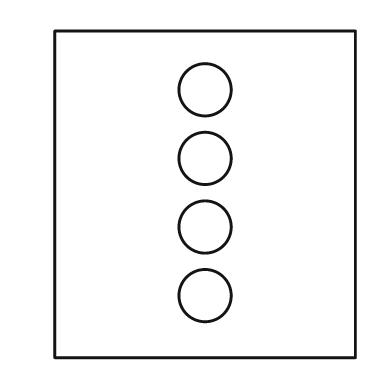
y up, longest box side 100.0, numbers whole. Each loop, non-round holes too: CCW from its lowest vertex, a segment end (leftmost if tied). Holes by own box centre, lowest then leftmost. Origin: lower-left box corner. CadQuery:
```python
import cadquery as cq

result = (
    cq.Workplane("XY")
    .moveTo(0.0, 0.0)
    .lineTo(92.0, 0.0)
    .lineTo(92.0, 100.0)
    .lineTo(0.0, 100.0)
    .close()
    .moveTo(46.0, 19.0)
    .circle(8.0)
    .moveTo(46.0, 40.0)
    .circle(8.0)
    .moveTo(46.0, 61.0)
    .circle(8.0)
    .moveTo(46.0, 82.0)
    .circle(8.0)
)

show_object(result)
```